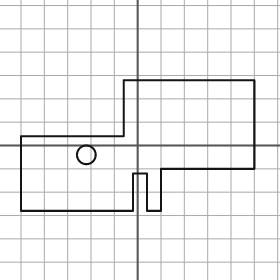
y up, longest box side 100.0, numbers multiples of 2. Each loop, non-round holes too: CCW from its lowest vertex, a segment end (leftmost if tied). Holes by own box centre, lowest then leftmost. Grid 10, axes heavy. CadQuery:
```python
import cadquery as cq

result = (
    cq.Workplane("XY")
    .moveTo(-50.0, -28.0)
    .lineTo(-2.0, -28.0)
    .lineTo(-2.0, -12.0)
    .lineTo(4.0, -12.0)
    .lineTo(4.0, -28.0)
    .lineTo(10.0, -28.0)
    .lineTo(10.0, -10.0)
    .lineTo(50.0, -10.0)
    .lineTo(50.0, 28.0)
    .lineTo(-6.0, 28.0)
    .lineTo(-6.0, 4.0)
    .lineTo(-50.0, 4.0)
    .close()
    .moveTo(-22.0, -4.0)
    .circle(4.0)
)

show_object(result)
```